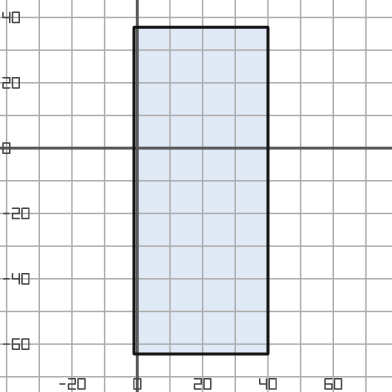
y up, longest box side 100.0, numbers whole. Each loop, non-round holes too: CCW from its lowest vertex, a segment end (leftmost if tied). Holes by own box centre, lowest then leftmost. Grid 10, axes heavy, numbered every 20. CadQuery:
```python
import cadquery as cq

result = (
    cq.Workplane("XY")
    .moveTo(-1.0, -63.0)
    .lineTo(40.0, -63.0)
    .lineTo(40.0, 37.0)
    .lineTo(-1.0, 37.0)
    .close()
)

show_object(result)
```